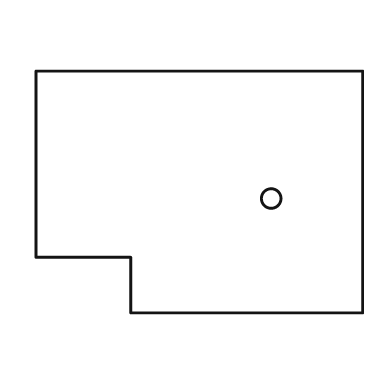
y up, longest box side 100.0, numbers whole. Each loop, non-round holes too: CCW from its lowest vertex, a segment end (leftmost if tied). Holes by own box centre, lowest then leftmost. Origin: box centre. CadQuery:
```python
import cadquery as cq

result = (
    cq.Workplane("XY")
    .moveTo(-21.0, -37.0)
    .lineTo(50.0, -37.0)
    .lineTo(50.0, 37.0)
    .lineTo(-50.0, 37.0)
    .lineTo(-50.0, -20.0)
    .lineTo(-21.0, -20.0)
    .close()
    .moveTo(22.0, -2.0)
    .circle(3.0)
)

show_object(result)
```